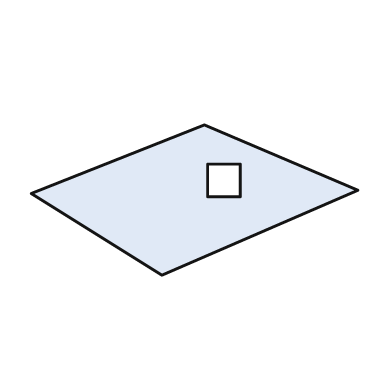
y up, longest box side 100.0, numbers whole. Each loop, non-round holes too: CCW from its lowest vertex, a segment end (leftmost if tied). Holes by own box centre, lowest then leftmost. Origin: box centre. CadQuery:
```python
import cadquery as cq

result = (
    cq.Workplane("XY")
    .moveTo(-10.0, -23.0)
    .lineTo(50.0, 3.0)
    .lineTo(3.0, 23.0)
    .lineTo(-50.0, 2.0)
    .close()
    .moveTo(4.0, 1.0)
    .lineTo(14.0, 1.0)
    .lineTo(14.0, 11.0)
    .lineTo(4.0, 11.0)
    .close()
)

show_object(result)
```